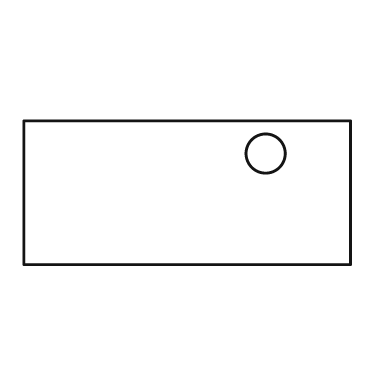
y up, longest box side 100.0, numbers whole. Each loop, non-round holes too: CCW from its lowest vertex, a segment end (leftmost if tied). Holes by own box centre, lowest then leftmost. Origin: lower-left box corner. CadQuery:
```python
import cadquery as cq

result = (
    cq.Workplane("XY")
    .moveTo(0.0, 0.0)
    .lineTo(100.0, 0.0)
    .lineTo(100.0, 44.0)
    .lineTo(0.0, 44.0)
    .close()
    .moveTo(74.0, 34.0)
    .circle(6.0)
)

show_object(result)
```